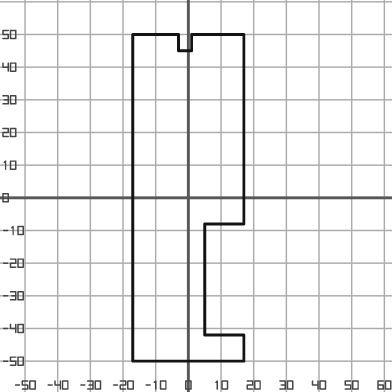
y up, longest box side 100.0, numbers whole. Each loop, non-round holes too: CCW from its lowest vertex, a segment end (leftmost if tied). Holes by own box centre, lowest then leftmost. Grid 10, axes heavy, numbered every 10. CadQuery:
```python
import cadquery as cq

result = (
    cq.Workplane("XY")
    .moveTo(-17.0, -50.0)
    .lineTo(17.0, -50.0)
    .lineTo(17.0, -42.0)
    .lineTo(5.0, -42.0)
    .lineTo(5.0, -8.0)
    .lineTo(17.0, -8.0)
    .lineTo(17.0, 50.0)
    .lineTo(1.0, 50.0)
    .lineTo(1.0, 45.0)
    .lineTo(-3.0, 45.0)
    .lineTo(-3.0, 50.0)
    .lineTo(-17.0, 50.0)
    .close()
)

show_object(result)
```